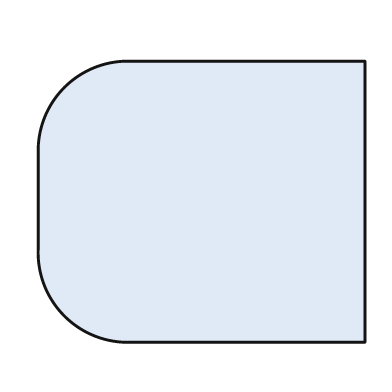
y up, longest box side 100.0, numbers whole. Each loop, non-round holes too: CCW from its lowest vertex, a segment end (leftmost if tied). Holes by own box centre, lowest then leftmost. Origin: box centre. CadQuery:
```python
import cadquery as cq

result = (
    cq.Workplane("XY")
    .moveTo(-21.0, -43.0)
    .lineTo(50.0, -43.0)
    .lineTo(50.0, 43.0)
    .lineTo(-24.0, 43.0)
    .threePointArc((-42.0, 35.0), (-50.0, 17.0))
    .lineTo(-50.0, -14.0)
    .threePointArc((-42.0, -35.0), (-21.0, -43.0))
    .close()
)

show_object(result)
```